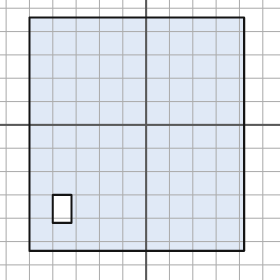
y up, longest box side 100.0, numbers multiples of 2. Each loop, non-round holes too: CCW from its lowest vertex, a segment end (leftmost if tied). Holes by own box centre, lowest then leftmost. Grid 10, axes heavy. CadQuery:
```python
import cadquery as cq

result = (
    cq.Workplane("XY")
    .moveTo(-50.0, -54.0)
    .lineTo(42.0, -54.0)
    .lineTo(42.0, 46.0)
    .lineTo(-50.0, 46.0)
    .close()
    .moveTo(-40.0, -42.0)
    .lineTo(-32.0, -42.0)
    .lineTo(-32.0, -30.0)
    .lineTo(-40.0, -30.0)
    .close()
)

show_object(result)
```